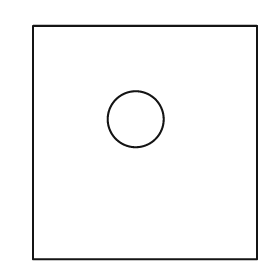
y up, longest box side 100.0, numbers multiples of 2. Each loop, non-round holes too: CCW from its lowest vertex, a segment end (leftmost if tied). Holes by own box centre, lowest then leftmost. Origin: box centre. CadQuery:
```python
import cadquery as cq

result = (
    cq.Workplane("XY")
    .moveTo(-48.0, -50.0)
    .lineTo(48.0, -50.0)
    .lineTo(48.0, 50.0)
    .lineTo(-48.0, 50.0)
    .close()
    .moveTo(-4.0, 10.0)
    .circle(12.0)
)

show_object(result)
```